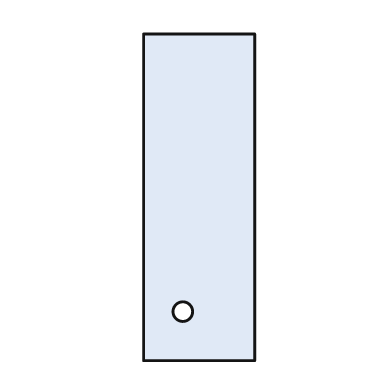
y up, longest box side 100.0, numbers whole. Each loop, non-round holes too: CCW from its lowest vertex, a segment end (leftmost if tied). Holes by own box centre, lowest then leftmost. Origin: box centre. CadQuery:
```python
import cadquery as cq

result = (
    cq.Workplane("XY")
    .moveTo(-17.0, -50.0)
    .lineTo(17.0, -50.0)
    .lineTo(17.0, 50.0)
    .lineTo(-17.0, 50.0)
    .close()
    .moveTo(-5.0, -35.0)
    .circle(3.0)
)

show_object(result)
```